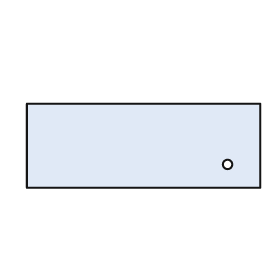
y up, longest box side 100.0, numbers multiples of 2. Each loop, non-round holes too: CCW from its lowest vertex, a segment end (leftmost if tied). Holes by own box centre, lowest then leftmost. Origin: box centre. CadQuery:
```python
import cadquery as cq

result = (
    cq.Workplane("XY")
    .moveTo(-50.0, -18.0)
    .lineTo(50.0, -18.0)
    .lineTo(50.0, 18.0)
    .lineTo(-50.0, 18.0)
    .close()
    .moveTo(36.0, -8.0)
    .circle(2.0)
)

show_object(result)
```